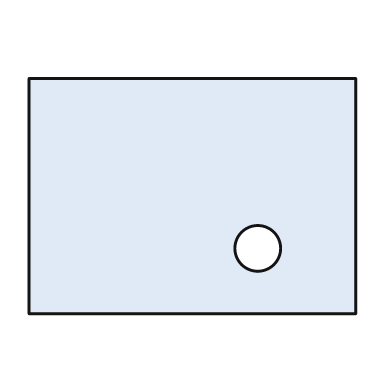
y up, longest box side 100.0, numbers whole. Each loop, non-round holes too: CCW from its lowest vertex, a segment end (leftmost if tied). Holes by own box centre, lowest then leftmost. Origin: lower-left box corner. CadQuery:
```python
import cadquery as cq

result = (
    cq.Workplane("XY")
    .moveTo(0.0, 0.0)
    .lineTo(100.0, 0.0)
    .lineTo(100.0, 72.0)
    .lineTo(0.0, 72.0)
    .close()
    .moveTo(70.0, 20.0)
    .circle(7.0)
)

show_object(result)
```